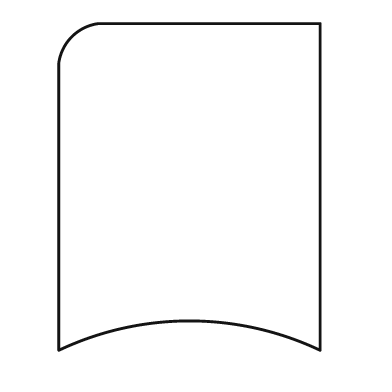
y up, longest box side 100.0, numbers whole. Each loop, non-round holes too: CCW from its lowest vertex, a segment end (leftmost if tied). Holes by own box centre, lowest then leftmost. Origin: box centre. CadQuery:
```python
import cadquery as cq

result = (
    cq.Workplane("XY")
    .moveTo(-40.0, -50.0)
    .threePointArc((0.0, -41.0), (40.0, -50.0))
    .lineTo(40.0, 50.0)
    .lineTo(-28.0, 50.0)
    .threePointArc((-36.0, 46.0), (-40.0, 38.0))
    .close()
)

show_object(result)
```